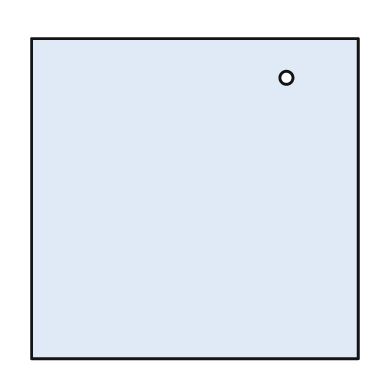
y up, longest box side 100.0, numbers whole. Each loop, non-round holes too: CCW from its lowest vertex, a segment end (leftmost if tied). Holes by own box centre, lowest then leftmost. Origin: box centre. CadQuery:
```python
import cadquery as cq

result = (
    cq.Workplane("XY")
    .moveTo(-50.0, -49.0)
    .lineTo(50.0, -49.0)
    .lineTo(50.0, 49.0)
    .lineTo(-50.0, 49.0)
    .close()
    .moveTo(28.0, 37.0)
    .circle(2.0)
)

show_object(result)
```